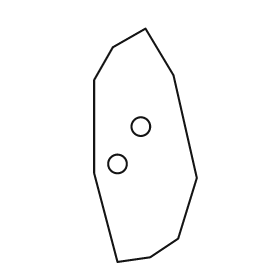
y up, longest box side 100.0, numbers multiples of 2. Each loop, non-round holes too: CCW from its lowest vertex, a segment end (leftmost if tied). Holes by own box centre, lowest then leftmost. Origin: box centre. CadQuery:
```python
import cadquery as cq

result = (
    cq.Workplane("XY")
    .moveTo(-12.0, -50.0)
    .lineTo(2.0, -48.0)
    .lineTo(14.0, -40.0)
    .lineTo(22.0, -14.0)
    .lineTo(12.0, 30.0)
    .lineTo(0.0, 50.0)
    .lineTo(-14.0, 42.0)
    .lineTo(-22.0, 28.0)
    .lineTo(-22.0, -12.0)
    .close()
    .moveTo(-12.0, -8.0)
    .circle(4.0)
    .moveTo(-2.0, 8.0)
    .circle(4.0)
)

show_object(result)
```